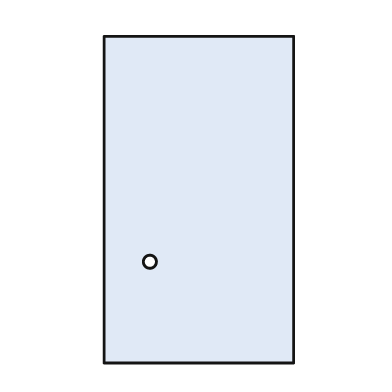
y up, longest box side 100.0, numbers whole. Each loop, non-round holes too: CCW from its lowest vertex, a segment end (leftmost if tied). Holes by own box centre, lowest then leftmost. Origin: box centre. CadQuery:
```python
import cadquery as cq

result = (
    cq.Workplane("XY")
    .moveTo(-29.0, -50.0)
    .lineTo(29.0, -50.0)
    .lineTo(29.0, 50.0)
    .lineTo(-29.0, 50.0)
    .close()
    .moveTo(-15.0, -19.0)
    .circle(2.0)
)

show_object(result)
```